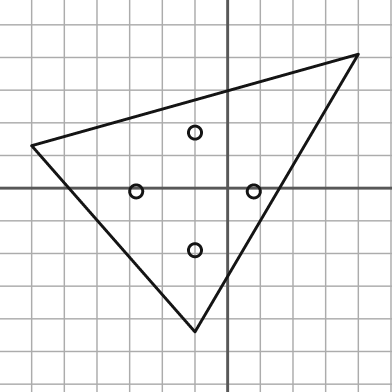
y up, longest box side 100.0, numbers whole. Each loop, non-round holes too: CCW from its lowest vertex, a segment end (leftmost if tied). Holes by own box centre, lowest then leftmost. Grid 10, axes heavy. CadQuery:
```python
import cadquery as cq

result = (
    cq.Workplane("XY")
    .moveTo(-10.0, -44.0)
    .lineTo(40.0, 41.0)
    .lineTo(-60.0, 13.0)
    .close()
    .moveTo(-10.0, -19.0)
    .circle(2.0)
    .moveTo(-28.0, -1.0)
    .circle(2.0)
    .moveTo(8.0, -1.0)
    .circle(2.0)
    .moveTo(-10.0, 17.0)
    .circle(2.0)
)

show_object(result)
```